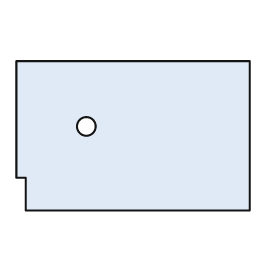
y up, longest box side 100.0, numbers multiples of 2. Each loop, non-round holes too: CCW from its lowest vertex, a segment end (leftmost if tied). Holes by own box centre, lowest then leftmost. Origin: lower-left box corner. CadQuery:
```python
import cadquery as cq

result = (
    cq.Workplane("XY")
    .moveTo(4.0, 0.0)
    .lineTo(100.0, 0.0)
    .lineTo(100.0, 64.0)
    .lineTo(0.0, 64.0)
    .lineTo(0.0, 14.0)
    .lineTo(4.0, 14.0)
    .close()
    .moveTo(30.0, 36.0)
    .circle(4.0)
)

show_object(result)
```